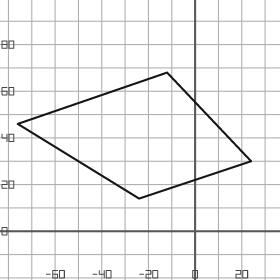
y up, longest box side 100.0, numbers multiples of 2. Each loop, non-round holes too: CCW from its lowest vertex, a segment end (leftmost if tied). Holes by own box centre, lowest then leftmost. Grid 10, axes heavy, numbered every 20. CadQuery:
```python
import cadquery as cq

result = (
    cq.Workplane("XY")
    .moveTo(-24.0, 14.0)
    .lineTo(24.0, 30.0)
    .lineTo(-12.0, 68.0)
    .lineTo(-76.0, 46.0)
    .close()
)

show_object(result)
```